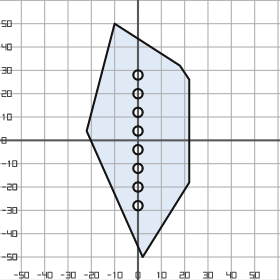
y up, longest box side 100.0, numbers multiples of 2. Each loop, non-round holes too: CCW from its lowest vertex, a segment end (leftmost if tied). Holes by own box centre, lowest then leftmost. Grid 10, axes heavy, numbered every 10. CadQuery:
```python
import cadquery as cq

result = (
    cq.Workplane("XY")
    .moveTo(2.0, -50.0)
    .lineTo(22.0, -18.0)
    .lineTo(22.0, 26.0)
    .lineTo(18.0, 32.0)
    .lineTo(-10.0, 50.0)
    .lineTo(-22.0, 4.0)
    .close()
    .moveTo(0.0, -28.0)
    .circle(2.0)
    .moveTo(0.0, -20.0)
    .circle(2.0)
    .moveTo(0.0, -12.0)
    .circle(2.0)
    .moveTo(0.0, -4.0)
    .circle(2.0)
    .moveTo(0.0, 4.0)
    .circle(2.0)
    .moveTo(0.0, 12.0)
    .circle(2.0)
    .moveTo(0.0, 20.0)
    .circle(2.0)
    .moveTo(0.0, 28.0)
    .circle(2.0)
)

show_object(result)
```